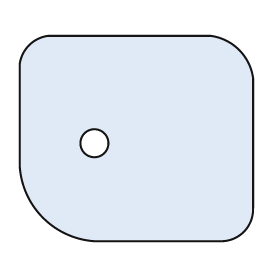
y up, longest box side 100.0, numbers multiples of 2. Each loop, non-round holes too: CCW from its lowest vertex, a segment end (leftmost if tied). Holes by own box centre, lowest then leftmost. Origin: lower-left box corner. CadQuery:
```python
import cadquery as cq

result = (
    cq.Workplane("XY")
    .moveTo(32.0, 0.0)
    .lineTo(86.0, 0.0)
    .threePointArc((96.0, 4.0), (100.0, 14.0))
    .lineTo(100.0, 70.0)
    .threePointArc((94.0, 82.0), (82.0, 88.0))
    .lineTo(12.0, 88.0)
    .threePointArc((4.0, 84.0), (0.0, 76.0))
    .lineTo(0.0, 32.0)
    .threePointArc((10.0, 10.0), (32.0, 0.0))
    .close()
    .moveTo(32.0, 42.0)
    .circle(6.0)
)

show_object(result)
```